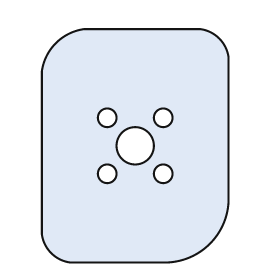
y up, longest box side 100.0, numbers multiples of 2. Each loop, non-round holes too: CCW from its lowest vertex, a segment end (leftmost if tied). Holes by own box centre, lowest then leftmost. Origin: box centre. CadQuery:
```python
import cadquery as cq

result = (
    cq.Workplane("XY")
    .moveTo(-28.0, -50.0)
    .lineTo(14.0, -50.0)
    .threePointArc((32.0, -42.0), (40.0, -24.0))
    .lineTo(40.0, 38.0)
    .threePointArc((36.0, 46.0), (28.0, 50.0))
    .lineTo(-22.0, 50.0)
    .threePointArc((-34.0, 44.0), (-40.0, 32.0))
    .lineTo(-40.0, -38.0)
    .threePointArc((-36.0, -46.0), (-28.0, -50.0))
    .close()
    .moveTo(-12.0, -12.0)
    .circle(4.0)
    .moveTo(12.0, -12.0)
    .circle(4.0)
    .moveTo(0.0, 0.0)
    .circle(8.0)
    .moveTo(-12.0, 12.0)
    .circle(4.0)
    .moveTo(12.0, 12.0)
    .circle(4.0)
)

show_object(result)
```